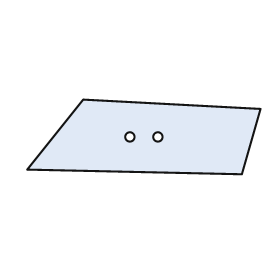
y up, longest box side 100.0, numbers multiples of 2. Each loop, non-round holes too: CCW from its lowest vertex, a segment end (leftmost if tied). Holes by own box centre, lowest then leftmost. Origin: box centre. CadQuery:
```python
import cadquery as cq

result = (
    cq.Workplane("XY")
    .moveTo(42.0, -16.0)
    .lineTo(50.0, 12.0)
    .lineTo(-26.0, 16.0)
    .lineTo(-50.0, -14.0)
    .close()
    .moveTo(-6.0, 0.0)
    .circle(2.0)
    .moveTo(6.0, 0.0)
    .circle(2.0)
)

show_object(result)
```